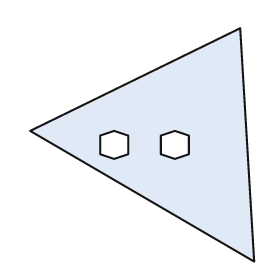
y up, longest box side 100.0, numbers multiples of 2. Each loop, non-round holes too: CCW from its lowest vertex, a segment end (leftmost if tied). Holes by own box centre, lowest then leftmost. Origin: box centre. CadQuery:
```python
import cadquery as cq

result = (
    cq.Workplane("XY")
    .moveTo(48.0, -50.0)
    .lineTo(42.0, 50.0)
    .lineTo(-48.0, 6.0)
    .close()
    .moveTo(-12.0, -6.0)
    .lineTo(-6.0, -4.0)
    .lineTo(-6.0, 4.0)
    .lineTo(-12.0, 6.0)
    .lineTo(-18.0, 4.0)
    .lineTo(-18.0, -4.0)
    .close()
    .moveTo(14.0, -6.0)
    .lineTo(20.0, -4.0)
    .lineTo(20.0, 4.0)
    .lineTo(14.0, 6.0)
    .lineTo(8.0, 4.0)
    .lineTo(8.0, -4.0)
    .close()
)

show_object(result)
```